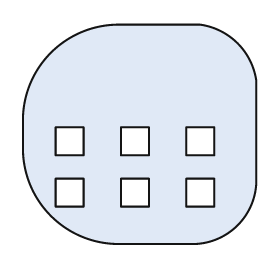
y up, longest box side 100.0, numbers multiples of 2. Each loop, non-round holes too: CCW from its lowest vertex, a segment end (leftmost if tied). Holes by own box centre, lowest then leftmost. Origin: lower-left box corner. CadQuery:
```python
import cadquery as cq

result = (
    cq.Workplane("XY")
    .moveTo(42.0, 0.0)
    .lineTo(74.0, 0.0)
    .threePointArc((92.0, 8.0), (100.0, 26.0))
    .lineTo(100.0, 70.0)
    .threePointArc((92.0, 86.0), (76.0, 94.0))
    .lineTo(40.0, 94.0)
    .threePointArc((12.0, 82.0), (0.0, 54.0))
    .lineTo(0.0, 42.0)
    .threePointArc((12.0, 12.0), (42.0, 0.0))
    .close()
    .moveTo(14.0, 16.0)
    .lineTo(26.0, 16.0)
    .lineTo(26.0, 28.0)
    .lineTo(14.0, 28.0)
    .close()
    .moveTo(42.0, 16.0)
    .lineTo(54.0, 16.0)
    .lineTo(54.0, 28.0)
    .lineTo(42.0, 28.0)
    .close()
    .moveTo(70.0, 16.0)
    .lineTo(82.0, 16.0)
    .lineTo(82.0, 28.0)
    .lineTo(70.0, 28.0)
    .close()
    .moveTo(14.0, 38.0)
    .lineTo(26.0, 38.0)
    .lineTo(26.0, 50.0)
    .lineTo(14.0, 50.0)
    .close()
    .moveTo(42.0, 38.0)
    .lineTo(54.0, 38.0)
    .lineTo(54.0, 50.0)
    .lineTo(42.0, 50.0)
    .close()
    .moveTo(70.0, 38.0)
    .lineTo(82.0, 38.0)
    .lineTo(82.0, 50.0)
    .lineTo(70.0, 50.0)
    .close()
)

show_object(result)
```